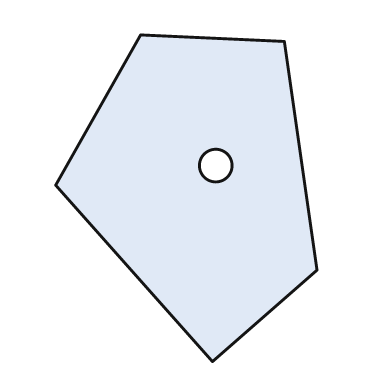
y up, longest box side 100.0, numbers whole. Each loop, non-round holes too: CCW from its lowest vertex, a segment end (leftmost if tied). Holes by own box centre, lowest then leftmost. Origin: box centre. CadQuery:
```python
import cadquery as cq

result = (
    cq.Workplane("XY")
    .moveTo(8.0, -50.0)
    .lineTo(40.0, -22.0)
    .lineTo(30.0, 48.0)
    .lineTo(-14.0, 50.0)
    .lineTo(-40.0, 4.0)
    .close()
    .moveTo(9.0, 10.0)
    .circle(5.0)
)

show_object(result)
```